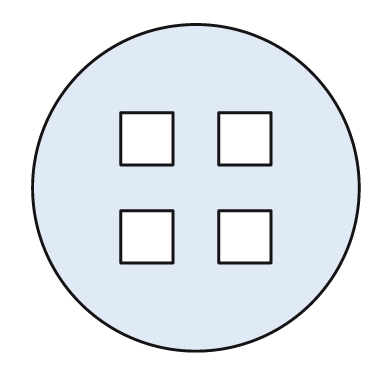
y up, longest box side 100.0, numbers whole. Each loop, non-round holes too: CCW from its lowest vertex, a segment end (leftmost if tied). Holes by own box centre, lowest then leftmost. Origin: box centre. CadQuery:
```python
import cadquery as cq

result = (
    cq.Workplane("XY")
    .moveTo(0.0, 0.0)
    .circle(50.0)
    .moveTo(-23.0, -23.0)
    .lineTo(-7.0, -23.0)
    .lineTo(-7.0, -7.0)
    .lineTo(-23.0, -7.0)
    .close()
    .moveTo(7.0, -23.0)
    .lineTo(23.0, -23.0)
    .lineTo(23.0, -7.0)
    .lineTo(7.0, -7.0)
    .close()
    .moveTo(-23.0, 7.0)
    .lineTo(-7.0, 7.0)
    .lineTo(-7.0, 23.0)
    .lineTo(-23.0, 23.0)
    .close()
    .moveTo(7.0, 7.0)
    .lineTo(23.0, 7.0)
    .lineTo(23.0, 23.0)
    .lineTo(7.0, 23.0)
    .close()
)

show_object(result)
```